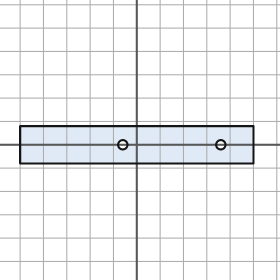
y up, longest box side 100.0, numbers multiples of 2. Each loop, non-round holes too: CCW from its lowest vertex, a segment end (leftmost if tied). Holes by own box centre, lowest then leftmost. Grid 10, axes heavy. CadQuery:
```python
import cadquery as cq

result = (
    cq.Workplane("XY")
    .moveTo(-50.0, -8.0)
    .lineTo(50.0, -8.0)
    .lineTo(50.0, 8.0)
    .lineTo(-50.0, 8.0)
    .close()
    .moveTo(-6.0, 0.0)
    .circle(2.0)
    .moveTo(36.0, 0.0)
    .circle(2.0)
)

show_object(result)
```